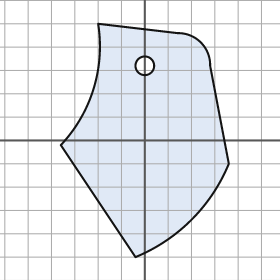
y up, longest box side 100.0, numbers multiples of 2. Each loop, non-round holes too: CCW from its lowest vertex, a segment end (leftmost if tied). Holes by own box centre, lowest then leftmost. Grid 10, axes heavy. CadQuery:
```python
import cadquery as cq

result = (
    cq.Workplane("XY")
    .moveTo(-4.0, -50.0)
    .threePointArc((20.0, -34.0), (36.0, -10.0))
    .lineTo(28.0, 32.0)
    .threePointArc((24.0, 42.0), (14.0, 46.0))
    .lineTo(-20.0, 50.0)
    .threePointArc((-22.0, 22.0), (-36.0, -2.0))
    .close()
    .moveTo(0.0, 32.0)
    .circle(4.0)
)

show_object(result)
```